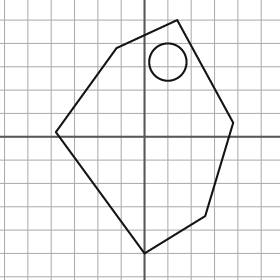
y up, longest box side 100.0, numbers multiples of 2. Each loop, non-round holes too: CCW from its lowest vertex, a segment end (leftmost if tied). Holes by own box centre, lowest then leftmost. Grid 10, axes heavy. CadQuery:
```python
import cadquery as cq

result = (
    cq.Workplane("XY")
    .moveTo(0.0, -50.0)
    .lineTo(26.0, -34.0)
    .lineTo(38.0, 6.0)
    .lineTo(14.0, 50.0)
    .lineTo(-12.0, 38.0)
    .lineTo(-38.0, 2.0)
    .close()
    .moveTo(10.0, 32.0)
    .circle(8.0)
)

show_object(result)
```